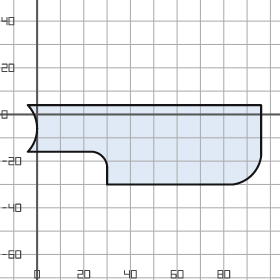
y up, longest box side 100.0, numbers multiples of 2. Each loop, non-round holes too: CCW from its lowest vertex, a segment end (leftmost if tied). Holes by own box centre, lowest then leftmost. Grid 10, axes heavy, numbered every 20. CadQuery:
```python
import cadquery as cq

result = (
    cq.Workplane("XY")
    .moveTo(30.0, -30.0)
    .lineTo(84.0, -30.0)
    .threePointArc((92.0, -26.0), (96.0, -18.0))
    .lineTo(96.0, 4.0)
    .lineTo(-4.0, 4.0)
    .threePointArc((0.0, -6.0), (-4.0, -16.0))
    .lineTo(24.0, -16.0)
    .threePointArc((28.0, -18.0), (30.0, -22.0))
    .close()
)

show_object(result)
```